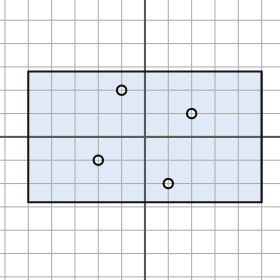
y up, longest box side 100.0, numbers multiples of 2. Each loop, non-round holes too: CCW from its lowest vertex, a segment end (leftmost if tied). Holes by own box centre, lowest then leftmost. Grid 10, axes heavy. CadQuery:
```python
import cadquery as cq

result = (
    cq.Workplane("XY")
    .moveTo(-50.0, -28.0)
    .lineTo(50.0, -28.0)
    .lineTo(50.0, 28.0)
    .lineTo(-50.0, 28.0)
    .close()
    .moveTo(10.0, -20.0)
    .circle(2.0)
    .moveTo(-20.0, -10.0)
    .circle(2.0)
    .moveTo(20.0, 10.0)
    .circle(2.0)
    .moveTo(-10.0, 20.0)
    .circle(2.0)
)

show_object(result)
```